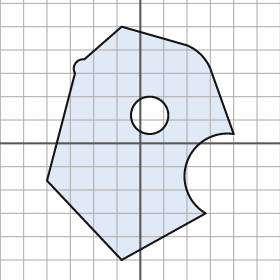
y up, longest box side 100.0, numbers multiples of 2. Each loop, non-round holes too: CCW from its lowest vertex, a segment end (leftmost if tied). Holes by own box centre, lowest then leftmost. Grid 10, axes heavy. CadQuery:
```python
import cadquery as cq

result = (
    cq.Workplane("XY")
    .moveTo(-8.0, -50.0)
    .lineTo(28.0, -30.0)
    .threePointArc((20.0, -8.0), (40.0, 4.0))
    .lineTo(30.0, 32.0)
    .threePointArc((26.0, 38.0), (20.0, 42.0))
    .lineTo(-8.0, 50.0)
    .lineTo(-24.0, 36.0)
    .threePointArc((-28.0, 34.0), (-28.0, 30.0))
    .lineTo(-40.0, -16.0)
    .close()
    .moveTo(4.0, 12.0)
    .circle(8.0)
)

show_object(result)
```